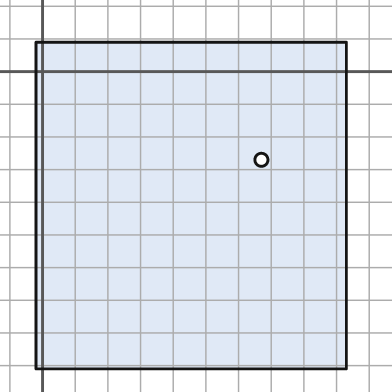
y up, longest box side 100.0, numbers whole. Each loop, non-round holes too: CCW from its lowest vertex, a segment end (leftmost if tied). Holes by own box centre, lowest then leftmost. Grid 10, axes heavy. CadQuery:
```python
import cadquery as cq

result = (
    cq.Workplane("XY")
    .moveTo(-2.0, -91.0)
    .lineTo(93.0, -91.0)
    .lineTo(93.0, 9.0)
    .lineTo(-2.0, 9.0)
    .close()
    .moveTo(67.0, -27.0)
    .circle(2.0)
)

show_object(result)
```